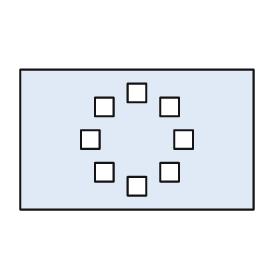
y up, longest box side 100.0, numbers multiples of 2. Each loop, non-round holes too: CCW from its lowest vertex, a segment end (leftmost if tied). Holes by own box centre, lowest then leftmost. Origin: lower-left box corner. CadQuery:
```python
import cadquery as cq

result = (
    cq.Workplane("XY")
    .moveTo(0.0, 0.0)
    .lineTo(100.0, 0.0)
    .lineTo(100.0, 60.0)
    .lineTo(0.0, 60.0)
    .close()
    .moveTo(46.0, 6.0)
    .lineTo(54.0, 6.0)
    .lineTo(54.0, 14.0)
    .lineTo(46.0, 14.0)
    .close()
    .moveTo(32.0, 12.0)
    .lineTo(40.0, 12.0)
    .lineTo(40.0, 20.0)
    .lineTo(32.0, 20.0)
    .close()
    .moveTo(60.0, 12.0)
    .lineTo(68.0, 12.0)
    .lineTo(68.0, 20.0)
    .lineTo(60.0, 20.0)
    .close()
    .moveTo(26.0, 26.0)
    .lineTo(34.0, 26.0)
    .lineTo(34.0, 34.0)
    .lineTo(26.0, 34.0)
    .close()
    .moveTo(66.0, 26.0)
    .lineTo(74.0, 26.0)
    .lineTo(74.0, 34.0)
    .lineTo(66.0, 34.0)
    .close()
    .moveTo(32.0, 40.0)
    .lineTo(40.0, 40.0)
    .lineTo(40.0, 48.0)
    .lineTo(32.0, 48.0)
    .close()
    .moveTo(60.0, 40.0)
    .lineTo(68.0, 40.0)
    .lineTo(68.0, 48.0)
    .lineTo(60.0, 48.0)
    .close()
    .moveTo(46.0, 46.0)
    .lineTo(54.0, 46.0)
    .lineTo(54.0, 54.0)
    .lineTo(46.0, 54.0)
    .close()
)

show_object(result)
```